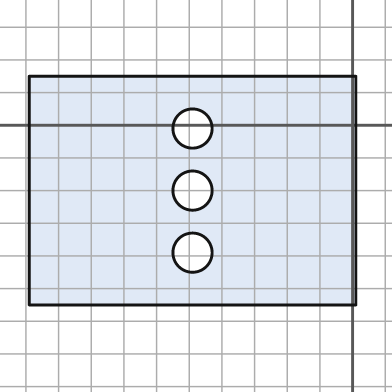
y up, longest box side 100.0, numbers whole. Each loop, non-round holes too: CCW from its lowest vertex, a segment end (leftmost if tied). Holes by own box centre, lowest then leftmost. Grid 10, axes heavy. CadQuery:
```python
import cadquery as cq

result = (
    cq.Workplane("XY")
    .moveTo(-99.0, -55.0)
    .lineTo(1.0, -55.0)
    .lineTo(1.0, 15.0)
    .lineTo(-99.0, 15.0)
    .close()
    .moveTo(-49.0, -39.0)
    .circle(6.0)
    .moveTo(-49.0, -20.0)
    .circle(6.0)
    .moveTo(-49.0, -1.0)
    .circle(6.0)
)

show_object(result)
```